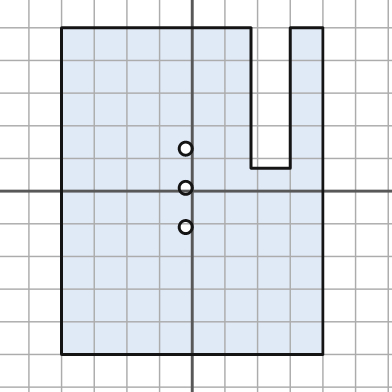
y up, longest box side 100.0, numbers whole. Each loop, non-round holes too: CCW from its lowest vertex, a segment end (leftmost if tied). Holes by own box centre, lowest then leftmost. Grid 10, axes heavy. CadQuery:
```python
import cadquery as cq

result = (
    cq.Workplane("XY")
    .moveTo(-40.0, -50.0)
    .lineTo(40.0, -50.0)
    .lineTo(40.0, 50.0)
    .lineTo(30.0, 50.0)
    .lineTo(30.0, 7.0)
    .lineTo(18.0, 7.0)
    .lineTo(18.0, 50.0)
    .lineTo(-40.0, 50.0)
    .close()
    .moveTo(-2.0, -11.0)
    .circle(2.0)
    .moveTo(-2.0, 1.0)
    .circle(2.0)
    .moveTo(-2.0, 13.0)
    .circle(2.0)
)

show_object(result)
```